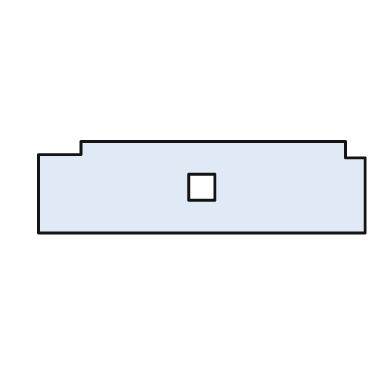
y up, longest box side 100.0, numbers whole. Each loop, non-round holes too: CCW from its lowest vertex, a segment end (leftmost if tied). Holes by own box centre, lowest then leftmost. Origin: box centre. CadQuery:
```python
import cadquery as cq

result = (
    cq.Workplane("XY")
    .moveTo(-50.0, -14.0)
    .lineTo(50.0, -14.0)
    .lineTo(50.0, 9.0)
    .lineTo(44.0, 9.0)
    .lineTo(44.0, 14.0)
    .lineTo(-37.0, 14.0)
    .lineTo(-37.0, 10.0)
    .lineTo(-50.0, 10.0)
    .close()
    .moveTo(-4.0, -4.0)
    .lineTo(4.0, -4.0)
    .lineTo(4.0, 4.0)
    .lineTo(-4.0, 4.0)
    .close()
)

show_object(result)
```